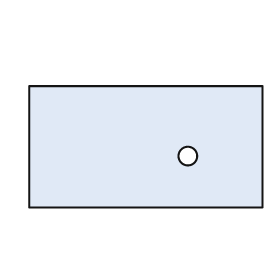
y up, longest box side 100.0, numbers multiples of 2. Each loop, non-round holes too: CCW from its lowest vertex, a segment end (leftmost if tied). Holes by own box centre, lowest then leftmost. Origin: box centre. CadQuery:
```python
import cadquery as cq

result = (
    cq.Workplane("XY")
    .moveTo(-50.0, -26.0)
    .lineTo(50.0, -26.0)
    .lineTo(50.0, 26.0)
    .lineTo(-50.0, 26.0)
    .close()
    .moveTo(18.0, -4.0)
    .circle(4.0)
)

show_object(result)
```